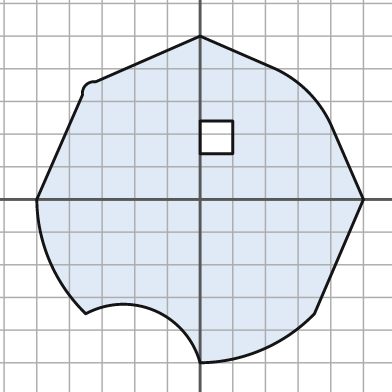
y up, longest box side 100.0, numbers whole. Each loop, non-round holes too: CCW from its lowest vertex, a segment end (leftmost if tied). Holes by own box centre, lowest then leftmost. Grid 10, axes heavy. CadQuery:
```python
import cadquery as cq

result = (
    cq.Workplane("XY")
    .moveTo(0.0, -50.0)
    .threePointArc((19.0, -46.0), (35.0, -35.0))
    .lineTo(50.0, 0.0)
    .lineTo(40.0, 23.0)
    .threePointArc((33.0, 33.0), (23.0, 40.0))
    .lineTo(0.0, 50.0)
    .lineTo(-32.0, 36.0)
    .threePointArc((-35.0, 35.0), (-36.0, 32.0))
    .lineTo(-50.0, 0.0)
    .threePointArc((-46.0, -19.0), (-35.0, -35.0))
    .threePointArc((-14.0, -34.0), (0.0, -50.0))
    .close()
    .moveTo(0.0, 14.0)
    .lineTo(10.0, 14.0)
    .lineTo(10.0, 24.0)
    .lineTo(0.0, 24.0)
    .close()
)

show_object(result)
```